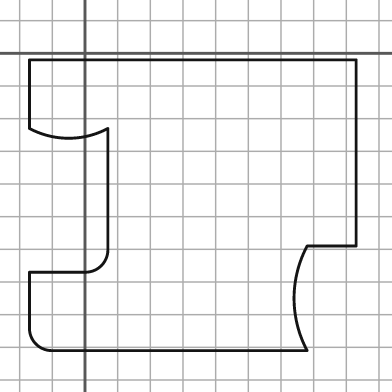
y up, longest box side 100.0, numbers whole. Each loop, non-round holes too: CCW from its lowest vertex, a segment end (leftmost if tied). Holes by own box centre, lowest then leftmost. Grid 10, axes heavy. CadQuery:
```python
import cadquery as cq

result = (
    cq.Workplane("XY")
    .moveTo(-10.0, -91.0)
    .lineTo(68.0, -91.0)
    .threePointArc((64.0, -75.0), (68.0, -59.0))
    .lineTo(83.0, -59.0)
    .lineTo(83.0, -2.0)
    .lineTo(-17.0, -2.0)
    .lineTo(-17.0, -23.0)
    .threePointArc((-5.0, -26.0), (7.0, -23.0))
    .lineTo(7.0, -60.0)
    .threePointArc((5.0, -65.0), (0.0, -67.0))
    .lineTo(-17.0, -67.0)
    .lineTo(-17.0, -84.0)
    .threePointArc((-15.0, -89.0), (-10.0, -91.0))
    .close()
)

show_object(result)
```